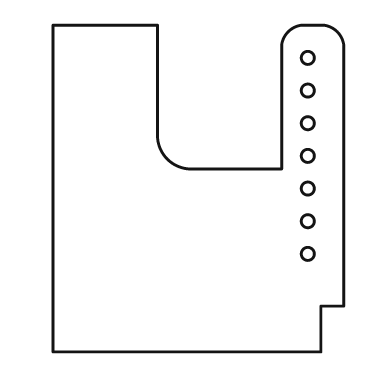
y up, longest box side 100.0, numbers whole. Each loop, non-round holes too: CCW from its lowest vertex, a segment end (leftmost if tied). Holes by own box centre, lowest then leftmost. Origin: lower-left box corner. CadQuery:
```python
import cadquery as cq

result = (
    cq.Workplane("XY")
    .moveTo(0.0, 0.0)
    .lineTo(82.0, 0.0)
    .lineTo(82.0, 14.0)
    .lineTo(89.0, 14.0)
    .lineTo(89.0, 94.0)
    .threePointArc((87.0, 98.0), (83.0, 100.0))
    .lineTo(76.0, 100.0)
    .threePointArc((72.0, 98.0), (70.0, 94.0))
    .lineTo(70.0, 56.0)
    .lineTo(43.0, 56.0)
    .threePointArc((35.0, 59.0), (32.0, 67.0))
    .lineTo(32.0, 100.0)
    .lineTo(0.0, 100.0)
    .close()
    .moveTo(78.0, 30.0)
    .circle(2.0)
    .moveTo(78.0, 40.0)
    .circle(2.0)
    .moveTo(78.0, 50.0)
    .circle(2.0)
    .moveTo(78.0, 60.0)
    .circle(2.0)
    .moveTo(78.0, 70.0)
    .circle(2.0)
    .moveTo(78.0, 80.0)
    .circle(2.0)
    .moveTo(78.0, 90.0)
    .circle(2.0)
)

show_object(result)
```